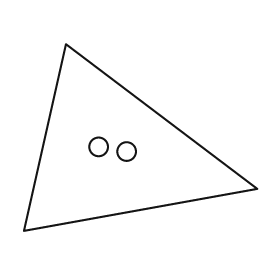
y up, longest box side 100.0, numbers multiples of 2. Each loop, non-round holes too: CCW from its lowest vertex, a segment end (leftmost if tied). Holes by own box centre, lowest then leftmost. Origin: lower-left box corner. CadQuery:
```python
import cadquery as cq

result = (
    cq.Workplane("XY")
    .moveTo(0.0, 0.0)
    .lineTo(100.0, 18.0)
    .lineTo(18.0, 80.0)
    .close()
    .moveTo(44.0, 34.0)
    .circle(4.0)
    .moveTo(32.0, 36.0)
    .circle(4.0)
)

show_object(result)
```